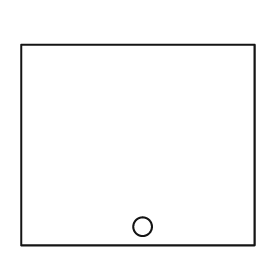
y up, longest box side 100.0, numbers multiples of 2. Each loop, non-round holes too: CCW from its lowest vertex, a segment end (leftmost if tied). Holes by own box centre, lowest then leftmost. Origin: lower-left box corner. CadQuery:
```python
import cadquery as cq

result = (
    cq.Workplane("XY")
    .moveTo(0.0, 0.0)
    .lineTo(100.0, 0.0)
    .lineTo(100.0, 86.0)
    .lineTo(0.0, 86.0)
    .close()
    .moveTo(52.0, 8.0)
    .circle(4.0)
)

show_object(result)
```